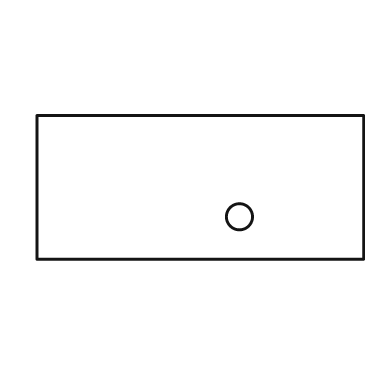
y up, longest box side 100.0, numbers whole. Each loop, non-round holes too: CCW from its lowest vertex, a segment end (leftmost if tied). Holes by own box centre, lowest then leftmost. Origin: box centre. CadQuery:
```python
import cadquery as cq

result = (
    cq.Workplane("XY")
    .moveTo(-50.0, -22.0)
    .lineTo(50.0, -22.0)
    .lineTo(50.0, 22.0)
    .lineTo(-50.0, 22.0)
    .close()
    .moveTo(12.0, -9.0)
    .circle(4.0)
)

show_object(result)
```